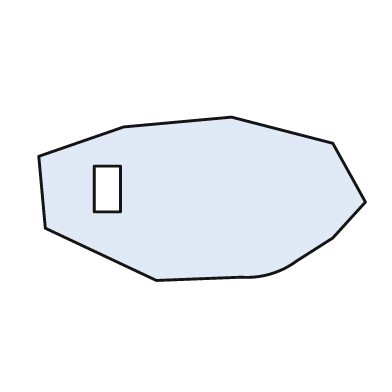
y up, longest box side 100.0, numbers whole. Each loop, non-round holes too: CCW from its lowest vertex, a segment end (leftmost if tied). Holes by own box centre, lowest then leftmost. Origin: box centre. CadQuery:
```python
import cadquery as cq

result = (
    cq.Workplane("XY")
    .moveTo(-14.0, -25.0)
    .lineTo(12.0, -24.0)
    .threePointArc((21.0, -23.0), (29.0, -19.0))
    .lineTo(40.0, -12.0)
    .lineTo(50.0, -1.0)
    .lineTo(40.0, 17.0)
    .lineTo(9.0, 25.0)
    .lineTo(-24.0, 22.0)
    .lineTo(-50.0, 13.0)
    .lineTo(-48.0, -9.0)
    .close()
    .moveTo(-33.0, -4.0)
    .lineTo(-25.0, -4.0)
    .lineTo(-25.0, 10.0)
    .lineTo(-33.0, 10.0)
    .close()
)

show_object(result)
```